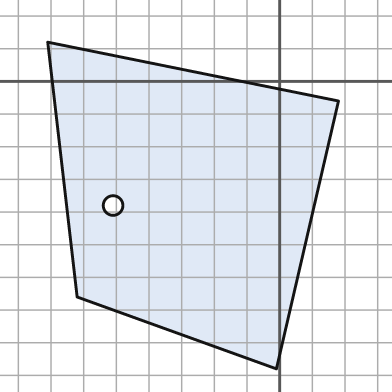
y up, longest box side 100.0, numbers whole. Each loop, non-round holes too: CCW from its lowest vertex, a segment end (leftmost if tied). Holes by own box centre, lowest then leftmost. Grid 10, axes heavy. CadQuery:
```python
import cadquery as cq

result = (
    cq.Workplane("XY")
    .moveTo(-1.0, -88.0)
    .lineTo(18.0, -6.0)
    .lineTo(-71.0, 12.0)
    .lineTo(-62.0, -66.0)
    .close()
    .moveTo(-51.0, -38.0)
    .circle(3.0)
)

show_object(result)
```